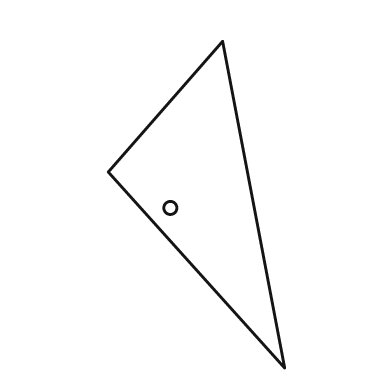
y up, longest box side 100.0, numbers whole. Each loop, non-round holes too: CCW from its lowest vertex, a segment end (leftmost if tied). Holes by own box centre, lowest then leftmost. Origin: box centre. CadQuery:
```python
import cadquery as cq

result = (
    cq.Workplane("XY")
    .moveTo(27.0, -50.0)
    .lineTo(8.0, 50.0)
    .lineTo(-27.0, 10.0)
    .close()
    .moveTo(-8.0, -1.0)
    .circle(2.0)
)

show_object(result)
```